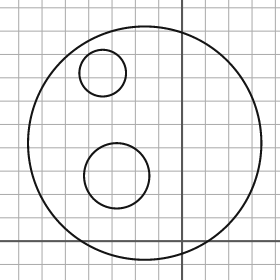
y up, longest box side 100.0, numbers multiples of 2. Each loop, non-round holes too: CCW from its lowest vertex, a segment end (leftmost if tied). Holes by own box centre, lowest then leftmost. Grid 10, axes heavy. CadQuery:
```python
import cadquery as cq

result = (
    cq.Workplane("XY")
    .moveTo(-16.0, 42.0)
    .circle(50.0)
    .moveTo(-28.0, 28.0)
    .circle(14.0)
    .moveTo(-34.0, 72.0)
    .circle(10.0)
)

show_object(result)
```